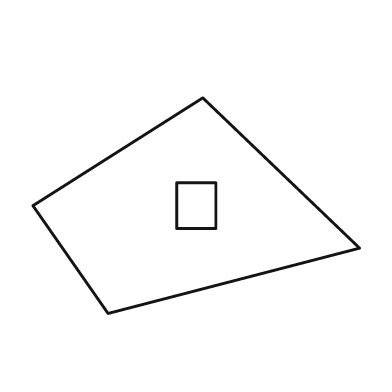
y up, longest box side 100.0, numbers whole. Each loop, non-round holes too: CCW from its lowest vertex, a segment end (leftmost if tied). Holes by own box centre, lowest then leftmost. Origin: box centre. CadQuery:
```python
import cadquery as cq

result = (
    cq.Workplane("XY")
    .moveTo(-27.0, -33.0)
    .lineTo(50.0, -13.0)
    .lineTo(2.0, 33.0)
    .lineTo(-50.0, 0.0)
    .close()
    .moveTo(-6.0, -7.0)
    .lineTo(6.0, -7.0)
    .lineTo(6.0, 7.0)
    .lineTo(-6.0, 7.0)
    .close()
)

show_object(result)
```